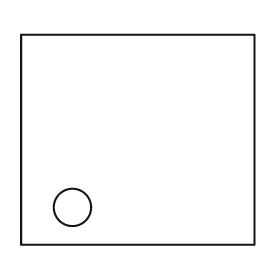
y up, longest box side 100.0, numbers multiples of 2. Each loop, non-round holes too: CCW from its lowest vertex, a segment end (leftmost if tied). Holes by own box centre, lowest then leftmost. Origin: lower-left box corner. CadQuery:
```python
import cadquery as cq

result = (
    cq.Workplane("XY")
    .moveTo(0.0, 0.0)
    .lineTo(100.0, 0.0)
    .lineTo(100.0, 90.0)
    .lineTo(0.0, 90.0)
    .close()
    .moveTo(22.0, 16.0)
    .circle(8.0)
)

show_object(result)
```